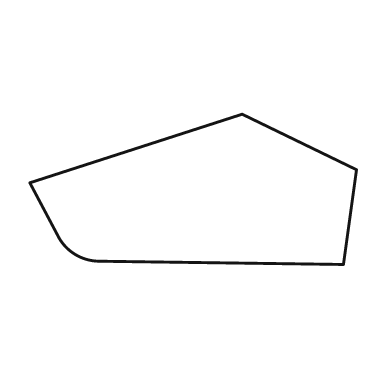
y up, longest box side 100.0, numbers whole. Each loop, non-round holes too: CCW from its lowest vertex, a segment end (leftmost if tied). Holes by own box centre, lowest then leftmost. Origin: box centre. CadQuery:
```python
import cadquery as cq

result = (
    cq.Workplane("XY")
    .moveTo(46.0, -23.0)
    .lineTo(50.0, 6.0)
    .lineTo(15.0, 23.0)
    .lineTo(-50.0, 2.0)
    .lineTo(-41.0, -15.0)
    .threePointArc((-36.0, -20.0), (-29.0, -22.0))
    .close()
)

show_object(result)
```